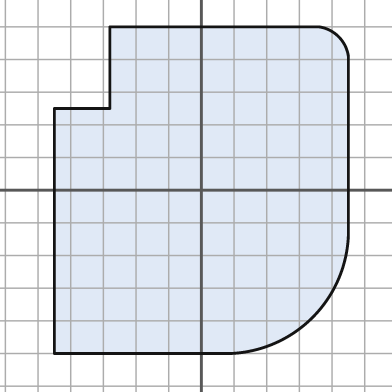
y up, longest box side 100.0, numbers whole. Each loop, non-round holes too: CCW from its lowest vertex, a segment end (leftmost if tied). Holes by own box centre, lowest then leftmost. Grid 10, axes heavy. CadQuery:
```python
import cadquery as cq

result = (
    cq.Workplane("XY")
    .moveTo(-45.0, -50.0)
    .lineTo(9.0, -50.0)
    .threePointArc((34.0, -39.0), (45.0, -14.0))
    .lineTo(45.0, 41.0)
    .threePointArc((42.0, 47.0), (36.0, 50.0))
    .lineTo(-28.0, 50.0)
    .lineTo(-28.0, 25.0)
    .lineTo(-45.0, 25.0)
    .close()
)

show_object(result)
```